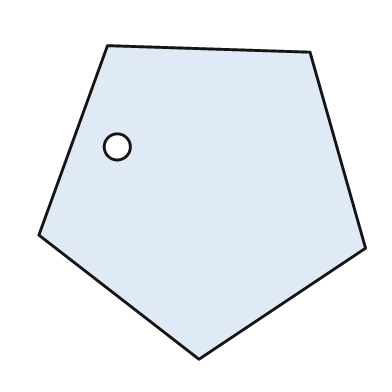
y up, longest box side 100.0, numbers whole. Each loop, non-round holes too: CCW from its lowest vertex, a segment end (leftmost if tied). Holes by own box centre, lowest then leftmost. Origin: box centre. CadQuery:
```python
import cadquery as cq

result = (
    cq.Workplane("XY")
    .moveTo(-1.0, -48.0)
    .lineTo(50.0, -14.0)
    .lineTo(33.0, 46.0)
    .lineTo(-29.0, 48.0)
    .lineTo(-50.0, -10.0)
    .close()
    .moveTo(-26.0, 17.0)
    .circle(4.0)
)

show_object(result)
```